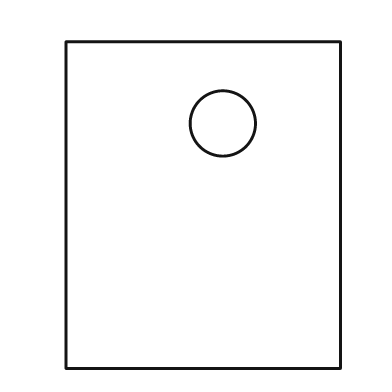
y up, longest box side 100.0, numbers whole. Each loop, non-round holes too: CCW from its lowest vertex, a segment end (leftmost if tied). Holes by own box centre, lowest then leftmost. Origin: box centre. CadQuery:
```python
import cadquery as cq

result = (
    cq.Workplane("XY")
    .moveTo(-42.0, -50.0)
    .lineTo(42.0, -50.0)
    .lineTo(42.0, 50.0)
    .lineTo(-42.0, 50.0)
    .close()
    .moveTo(6.0, 25.0)
    .circle(10.0)
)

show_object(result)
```